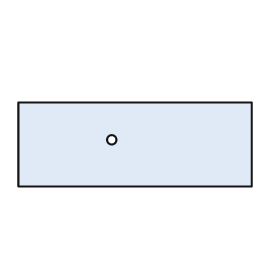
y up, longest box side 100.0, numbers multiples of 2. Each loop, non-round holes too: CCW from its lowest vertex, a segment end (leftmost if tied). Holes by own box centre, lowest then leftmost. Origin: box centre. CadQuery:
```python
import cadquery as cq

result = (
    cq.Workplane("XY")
    .moveTo(-50.0, -18.0)
    .lineTo(50.0, -18.0)
    .lineTo(50.0, 18.0)
    .lineTo(-50.0, 18.0)
    .close()
    .moveTo(-10.0, 2.0)
    .circle(2.0)
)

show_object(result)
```